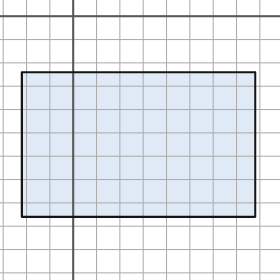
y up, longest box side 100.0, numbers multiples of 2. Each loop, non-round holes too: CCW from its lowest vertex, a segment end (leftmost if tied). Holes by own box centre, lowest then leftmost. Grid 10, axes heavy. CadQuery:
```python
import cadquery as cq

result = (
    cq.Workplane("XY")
    .moveTo(-22.0, -86.0)
    .lineTo(78.0, -86.0)
    .lineTo(78.0, -24.0)
    .lineTo(-22.0, -24.0)
    .close()
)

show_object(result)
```